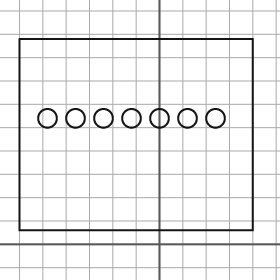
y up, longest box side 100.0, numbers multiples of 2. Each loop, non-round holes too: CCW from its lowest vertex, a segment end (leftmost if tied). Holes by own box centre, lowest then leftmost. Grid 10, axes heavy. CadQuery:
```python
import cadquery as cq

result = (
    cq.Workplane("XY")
    .moveTo(-60.0, 6.0)
    .lineTo(40.0, 6.0)
    .lineTo(40.0, 88.0)
    .lineTo(-60.0, 88.0)
    .close()
    .moveTo(-48.0, 54.0)
    .circle(4.0)
    .moveTo(-36.0, 54.0)
    .circle(4.0)
    .moveTo(-24.0, 54.0)
    .circle(4.0)
    .moveTo(-12.0, 54.0)
    .circle(4.0)
    .moveTo(0.0, 54.0)
    .circle(4.0)
    .moveTo(12.0, 54.0)
    .circle(4.0)
    .moveTo(24.0, 54.0)
    .circle(4.0)
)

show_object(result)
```